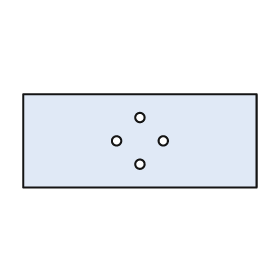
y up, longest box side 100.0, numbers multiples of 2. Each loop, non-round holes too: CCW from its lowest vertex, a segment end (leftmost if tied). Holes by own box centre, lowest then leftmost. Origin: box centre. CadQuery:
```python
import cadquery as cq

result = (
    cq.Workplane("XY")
    .moveTo(-50.0, -20.0)
    .lineTo(50.0, -20.0)
    .lineTo(50.0, 20.0)
    .lineTo(-50.0, 20.0)
    .close()
    .moveTo(0.0, -10.0)
    .circle(2.0)
    .moveTo(-10.0, 0.0)
    .circle(2.0)
    .moveTo(10.0, 0.0)
    .circle(2.0)
    .moveTo(0.0, 10.0)
    .circle(2.0)
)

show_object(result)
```